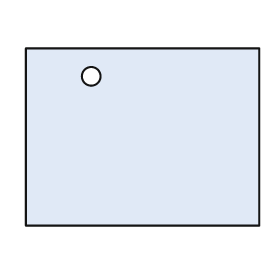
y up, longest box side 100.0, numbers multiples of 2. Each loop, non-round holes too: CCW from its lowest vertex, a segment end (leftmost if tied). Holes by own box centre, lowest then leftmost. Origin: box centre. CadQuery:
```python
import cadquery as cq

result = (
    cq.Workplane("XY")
    .moveTo(-50.0, -38.0)
    .lineTo(50.0, -38.0)
    .lineTo(50.0, 38.0)
    .lineTo(-50.0, 38.0)
    .close()
    .moveTo(-22.0, 26.0)
    .circle(4.0)
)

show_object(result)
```